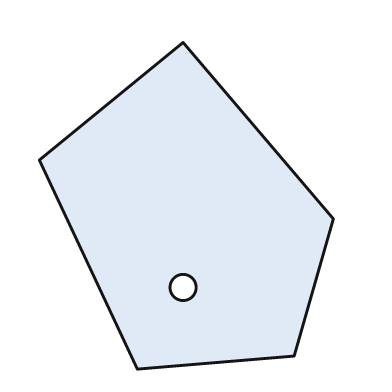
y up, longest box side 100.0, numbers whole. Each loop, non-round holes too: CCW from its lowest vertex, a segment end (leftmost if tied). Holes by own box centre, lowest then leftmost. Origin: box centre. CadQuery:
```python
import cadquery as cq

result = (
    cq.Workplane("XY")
    .moveTo(-15.0, -50.0)
    .lineTo(33.0, -46.0)
    .lineTo(45.0, -4.0)
    .lineTo(-1.0, 50.0)
    .lineTo(-45.0, 14.0)
    .close()
    .moveTo(-1.0, -25.0)
    .circle(4.0)
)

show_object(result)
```